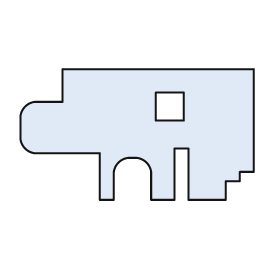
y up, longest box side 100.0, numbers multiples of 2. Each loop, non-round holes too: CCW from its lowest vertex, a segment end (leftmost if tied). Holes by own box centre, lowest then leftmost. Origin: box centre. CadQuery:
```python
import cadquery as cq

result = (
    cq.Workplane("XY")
    .moveTo(-16.0, -28.0)
    .lineTo(-10.0, -28.0)
    .lineTo(-10.0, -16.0)
    .threePointArc((-8.0, -12.0), (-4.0, -10.0))
    .lineTo(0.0, -10.0)
    .threePointArc((4.0, -12.0), (6.0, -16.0))
    .lineTo(6.0, -28.0)
    .lineTo(16.0, -28.0)
    .lineTo(16.0, -6.0)
    .lineTo(22.0, -6.0)
    .lineTo(22.0, -28.0)
    .lineTo(38.0, -28.0)
    .lineTo(38.0, -20.0)
    .lineTo(44.0, -20.0)
    .lineTo(44.0, -16.0)
    .lineTo(50.0, -16.0)
    .lineTo(50.0, 28.0)
    .lineTo(-32.0, 28.0)
    .lineTo(-32.0, 14.0)
    .lineTo(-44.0, 14.0)
    .threePointArc((-48.0, 12.0), (-50.0, 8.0))
    .lineTo(-50.0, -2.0)
    .threePointArc((-48.0, -6.0), (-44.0, -8.0))
    .lineTo(-16.0, -8.0)
    .close()
    .moveTo(8.0, 6.0)
    .lineTo(20.0, 6.0)
    .lineTo(20.0, 18.0)
    .lineTo(8.0, 18.0)
    .close()
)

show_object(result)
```